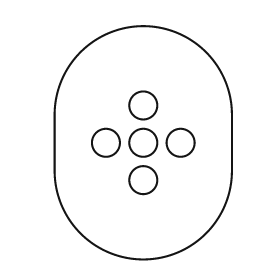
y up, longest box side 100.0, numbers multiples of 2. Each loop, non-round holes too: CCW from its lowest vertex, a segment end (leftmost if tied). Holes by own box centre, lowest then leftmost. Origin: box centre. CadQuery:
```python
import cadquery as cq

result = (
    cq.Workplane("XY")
    .moveTo(-38.0, -12.0)
    .threePointArc((0.0, -50.0), (38.0, -12.0))
    .lineTo(38.0, 12.0)
    .threePointArc((0.0, 50.0), (-38.0, 12.0))
    .close()
    .moveTo(0.0, -16.0)
    .circle(6.0)
    .moveTo(-16.0, 0.0)
    .circle(6.0)
    .moveTo(0.0, 0.0)
    .circle(6.0)
    .moveTo(16.0, 0.0)
    .circle(6.0)
    .moveTo(0.0, 16.0)
    .circle(6.0)
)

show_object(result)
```